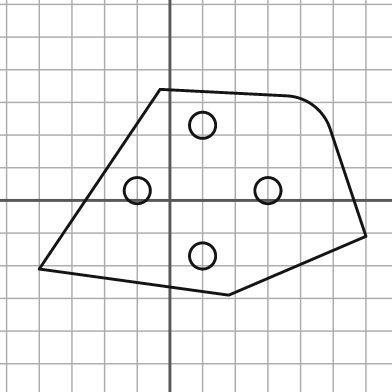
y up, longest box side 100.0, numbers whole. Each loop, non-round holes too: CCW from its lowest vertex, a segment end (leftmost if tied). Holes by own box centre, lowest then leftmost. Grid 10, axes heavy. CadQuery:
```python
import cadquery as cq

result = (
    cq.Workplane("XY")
    .moveTo(18.0, -29.0)
    .lineTo(60.0, -11.0)
    .lineTo(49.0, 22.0)
    .threePointArc((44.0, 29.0), (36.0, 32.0))
    .lineTo(-3.0, 34.0)
    .lineTo(-40.0, -21.0)
    .close()
    .moveTo(10.0, -17.0)
    .circle(4.0)
    .moveTo(-10.0, 3.0)
    .circle(4.0)
    .moveTo(30.0, 3.0)
    .circle(4.0)
    .moveTo(10.0, 23.0)
    .circle(4.0)
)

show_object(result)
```